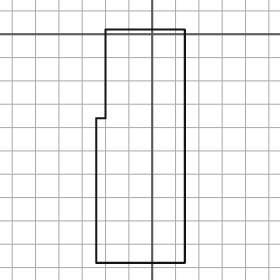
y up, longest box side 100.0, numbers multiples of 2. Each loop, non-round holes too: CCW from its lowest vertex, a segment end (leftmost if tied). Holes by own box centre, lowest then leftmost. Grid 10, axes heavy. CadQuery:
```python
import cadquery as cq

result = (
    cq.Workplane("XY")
    .moveTo(-24.0, -98.0)
    .lineTo(14.0, -98.0)
    .lineTo(14.0, 2.0)
    .lineTo(-20.0, 2.0)
    .lineTo(-20.0, -36.0)
    .lineTo(-24.0, -36.0)
    .close()
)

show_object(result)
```